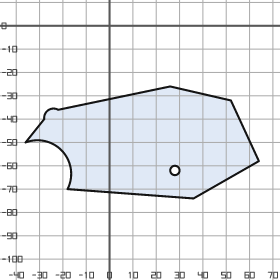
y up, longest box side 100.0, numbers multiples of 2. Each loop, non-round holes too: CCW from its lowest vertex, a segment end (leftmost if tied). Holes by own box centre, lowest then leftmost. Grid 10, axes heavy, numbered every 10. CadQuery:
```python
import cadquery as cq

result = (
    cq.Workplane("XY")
    .moveTo(36.0, -74.0)
    .lineTo(64.0, -58.0)
    .lineTo(52.0, -32.0)
    .lineTo(26.0, -26.0)
    .lineTo(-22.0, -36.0)
    .threePointArc((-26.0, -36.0), (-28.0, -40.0))
    .lineTo(-36.0, -50.0)
    .threePointArc((-20.0, -54.0), (-18.0, -70.0))
    .close()
    .moveTo(28.0, -62.0)
    .circle(2.0)
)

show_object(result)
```